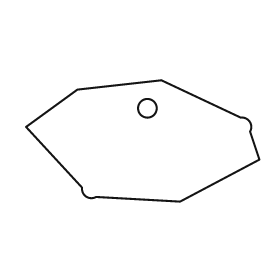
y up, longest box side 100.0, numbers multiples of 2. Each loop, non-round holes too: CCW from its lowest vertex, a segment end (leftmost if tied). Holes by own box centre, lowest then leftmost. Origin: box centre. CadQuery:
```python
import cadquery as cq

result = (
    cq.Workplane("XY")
    .moveTo(16.0, -26.0)
    .lineTo(50.0, -8.0)
    .lineTo(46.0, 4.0)
    .threePointArc((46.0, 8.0), (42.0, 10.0))
    .lineTo(8.0, 26.0)
    .lineTo(-28.0, 22.0)
    .lineTo(-50.0, 6.0)
    .lineTo(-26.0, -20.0)
    .threePointArc((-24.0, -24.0), (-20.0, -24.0))
    .close()
    .moveTo(2.0, 14.0)
    .circle(4.0)
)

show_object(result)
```